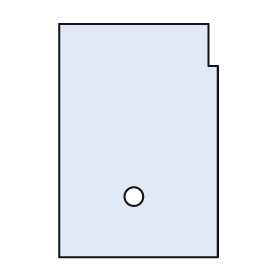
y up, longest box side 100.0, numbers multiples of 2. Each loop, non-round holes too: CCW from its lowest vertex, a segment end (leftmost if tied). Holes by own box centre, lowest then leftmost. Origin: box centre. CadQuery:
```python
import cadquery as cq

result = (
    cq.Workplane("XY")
    .moveTo(-34.0, -50.0)
    .lineTo(34.0, -50.0)
    .lineTo(34.0, 32.0)
    .lineTo(30.0, 32.0)
    .lineTo(30.0, 50.0)
    .lineTo(-34.0, 50.0)
    .close()
    .moveTo(-2.0, -24.0)
    .circle(4.0)
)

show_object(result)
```